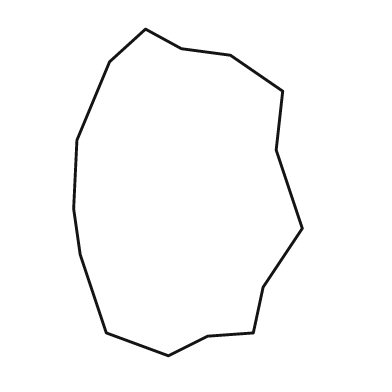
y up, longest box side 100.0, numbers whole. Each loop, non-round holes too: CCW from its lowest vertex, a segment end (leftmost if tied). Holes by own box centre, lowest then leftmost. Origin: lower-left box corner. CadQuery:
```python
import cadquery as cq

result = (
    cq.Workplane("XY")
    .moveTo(29.0, 0.0)
    .lineTo(41.0, 6.0)
    .lineTo(55.0, 7.0)
    .lineTo(58.0, 21.0)
    .lineTo(70.0, 39.0)
    .lineTo(62.0, 63.0)
    .lineTo(64.0, 81.0)
    .lineTo(48.0, 92.0)
    .lineTo(33.0, 94.0)
    .lineTo(22.0, 100.0)
    .lineTo(11.0, 90.0)
    .lineTo(1.0, 66.0)
    .lineTo(0.0, 45.0)
    .lineTo(2.0, 31.0)
    .lineTo(10.0, 7.0)
    .close()
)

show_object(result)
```